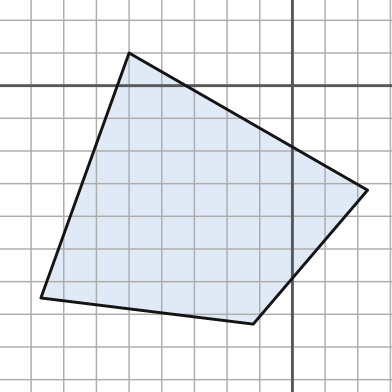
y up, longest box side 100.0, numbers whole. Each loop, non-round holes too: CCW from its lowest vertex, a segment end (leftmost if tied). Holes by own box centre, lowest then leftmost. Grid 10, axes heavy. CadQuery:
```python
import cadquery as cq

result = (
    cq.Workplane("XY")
    .moveTo(-12.0, -73.0)
    .lineTo(23.0, -32.0)
    .lineTo(-50.0, 10.0)
    .lineTo(-77.0, -65.0)
    .close()
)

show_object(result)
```